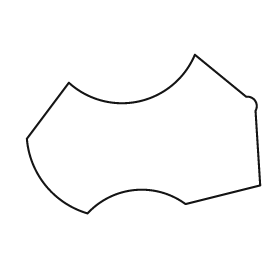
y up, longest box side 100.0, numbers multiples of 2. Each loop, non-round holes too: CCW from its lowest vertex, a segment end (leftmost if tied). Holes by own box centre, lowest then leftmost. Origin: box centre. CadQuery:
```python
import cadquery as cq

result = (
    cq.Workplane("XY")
    .moveTo(-24.0, -34.0)
    .threePointArc((-4.0, -24.0), (18.0, -30.0))
    .lineTo(50.0, -22.0)
    .lineTo(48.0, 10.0)
    .threePointArc((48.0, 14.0), (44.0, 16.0))
    .lineTo(22.0, 34.0)
    .threePointArc((-2.0, 14.0), (-32.0, 22.0))
    .lineTo(-50.0, -2.0)
    .threePointArc((-42.0, -22.0), (-24.0, -34.0))
    .close()
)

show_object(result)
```